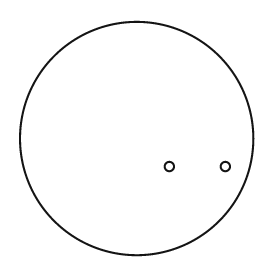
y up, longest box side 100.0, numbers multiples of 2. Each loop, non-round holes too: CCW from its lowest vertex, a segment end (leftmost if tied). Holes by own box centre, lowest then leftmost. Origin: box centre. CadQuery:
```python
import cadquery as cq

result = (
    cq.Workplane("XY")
    .moveTo(0.0, 0.0)
    .circle(50.0)
    .moveTo(14.0, -12.0)
    .circle(2.0)
    .moveTo(38.0, -12.0)
    .circle(2.0)
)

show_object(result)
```